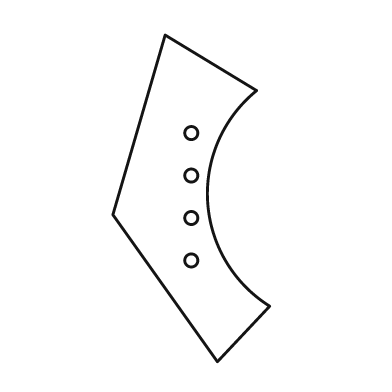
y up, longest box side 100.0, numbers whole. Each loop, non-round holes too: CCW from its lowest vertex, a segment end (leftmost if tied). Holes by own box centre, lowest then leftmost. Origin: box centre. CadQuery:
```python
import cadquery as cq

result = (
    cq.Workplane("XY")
    .moveTo(8.0, -50.0)
    .lineTo(24.0, -33.0)
    .threePointArc((5.0, -1.0), (20.0, 33.0))
    .lineTo(-8.0, 50.0)
    .lineTo(-24.0, -5.0)
    .close()
    .moveTo(0.0, -19.0)
    .circle(2.0)
    .moveTo(0.0, -6.0)
    .circle(2.0)
    .moveTo(0.0, 7.0)
    .circle(2.0)
    .moveTo(0.0, 20.0)
    .circle(2.0)
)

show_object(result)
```